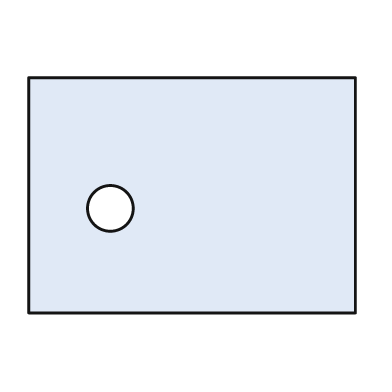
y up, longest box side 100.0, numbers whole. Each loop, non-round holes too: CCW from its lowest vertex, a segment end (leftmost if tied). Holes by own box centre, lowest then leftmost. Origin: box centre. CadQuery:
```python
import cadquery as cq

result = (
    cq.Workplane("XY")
    .moveTo(-50.0, -36.0)
    .lineTo(50.0, -36.0)
    .lineTo(50.0, 36.0)
    .lineTo(-50.0, 36.0)
    .close()
    .moveTo(-25.0, -4.0)
    .circle(7.0)
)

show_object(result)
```